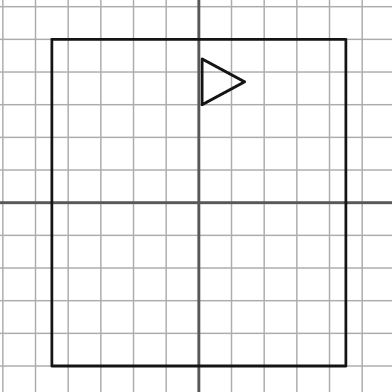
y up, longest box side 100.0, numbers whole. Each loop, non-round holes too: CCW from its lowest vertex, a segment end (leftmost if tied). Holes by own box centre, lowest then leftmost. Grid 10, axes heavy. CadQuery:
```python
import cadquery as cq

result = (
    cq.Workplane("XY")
    .moveTo(-45.0, -50.0)
    .lineTo(45.0, -50.0)
    .lineTo(45.0, 50.0)
    .lineTo(-45.0, 50.0)
    .close()
    .moveTo(1.0, 30.0)
    .lineTo(14.0, 37.0)
    .lineTo(1.0, 44.0)
    .close()
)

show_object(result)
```